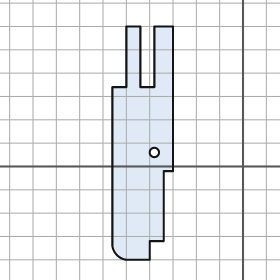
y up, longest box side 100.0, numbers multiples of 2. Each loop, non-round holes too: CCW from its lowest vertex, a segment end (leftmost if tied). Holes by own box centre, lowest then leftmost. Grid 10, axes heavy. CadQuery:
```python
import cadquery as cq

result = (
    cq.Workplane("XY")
    .moveTo(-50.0, -40.0)
    .lineTo(-40.0, -40.0)
    .lineTo(-40.0, -32.0)
    .lineTo(-34.0, -32.0)
    .lineTo(-34.0, -2.0)
    .lineTo(-30.0, -2.0)
    .lineTo(-30.0, 60.0)
    .lineTo(-38.0, 60.0)
    .lineTo(-38.0, 34.0)
    .lineTo(-44.0, 34.0)
    .lineTo(-44.0, 60.0)
    .lineTo(-50.0, 60.0)
    .lineTo(-50.0, 34.0)
    .lineTo(-56.0, 34.0)
    .lineTo(-56.0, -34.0)
    .threePointArc((-54.0, -38.0), (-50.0, -40.0))
    .close()
    .moveTo(-38.0, 6.0)
    .circle(2.0)
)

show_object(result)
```